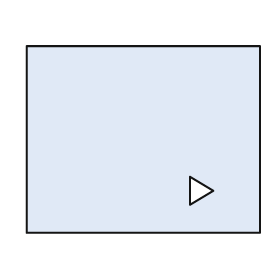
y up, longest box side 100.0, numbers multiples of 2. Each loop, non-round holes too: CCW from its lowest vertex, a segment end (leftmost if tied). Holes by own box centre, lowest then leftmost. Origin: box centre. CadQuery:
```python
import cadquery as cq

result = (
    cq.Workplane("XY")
    .moveTo(-50.0, -40.0)
    .lineTo(50.0, -40.0)
    .lineTo(50.0, 40.0)
    .lineTo(-50.0, 40.0)
    .close()
    .moveTo(20.0, -28.0)
    .lineTo(30.0, -22.0)
    .lineTo(20.0, -16.0)
    .close()
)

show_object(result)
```